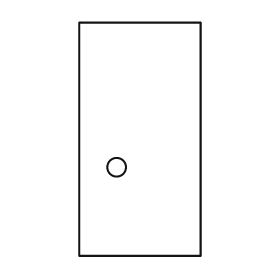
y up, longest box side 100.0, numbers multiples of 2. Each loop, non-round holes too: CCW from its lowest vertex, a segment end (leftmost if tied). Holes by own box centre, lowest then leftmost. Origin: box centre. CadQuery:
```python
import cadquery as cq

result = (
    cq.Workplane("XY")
    .moveTo(-26.0, -50.0)
    .lineTo(26.0, -50.0)
    .lineTo(26.0, 50.0)
    .lineTo(-26.0, 50.0)
    .close()
    .moveTo(-10.0, -12.0)
    .circle(4.0)
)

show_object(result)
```